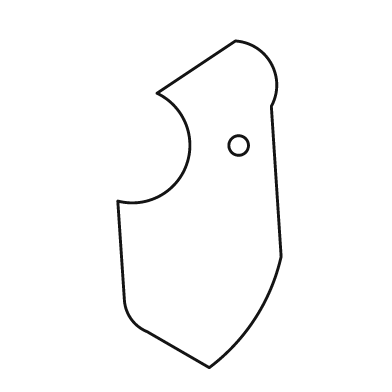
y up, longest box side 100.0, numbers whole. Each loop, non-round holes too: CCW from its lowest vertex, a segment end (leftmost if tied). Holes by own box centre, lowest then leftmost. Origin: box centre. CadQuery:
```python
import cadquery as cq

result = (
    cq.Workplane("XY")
    .moveTo(3.0, -50.0)
    .threePointArc((17.0, -35.0), (25.0, -16.0))
    .lineTo(22.0, 30.0)
    .threePointArc((22.0, 43.0), (11.0, 50.0))
    .lineTo(-13.0, 34.0)
    .threePointArc((-4.0, 12.0), (-25.0, 1.0))
    .lineTo(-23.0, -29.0)
    .threePointArc((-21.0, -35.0), (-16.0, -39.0))
    .close()
    .moveTo(12.0, 18.0)
    .circle(3.0)
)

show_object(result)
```